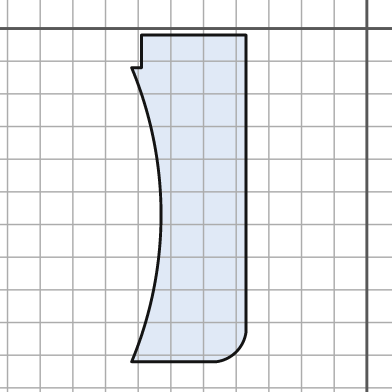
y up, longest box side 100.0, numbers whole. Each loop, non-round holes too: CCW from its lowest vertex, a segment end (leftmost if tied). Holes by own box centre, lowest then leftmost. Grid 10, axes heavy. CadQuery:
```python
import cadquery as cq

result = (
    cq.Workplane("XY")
    .moveTo(-72.0, -102.0)
    .lineTo(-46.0, -102.0)
    .threePointArc((-40.0, -99.0), (-37.0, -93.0))
    .lineTo(-37.0, -2.0)
    .lineTo(-69.0, -2.0)
    .lineTo(-69.0, -12.0)
    .lineTo(-72.0, -12.0)
    .threePointArc((-63.0, -57.0), (-72.0, -102.0))
    .close()
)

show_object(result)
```